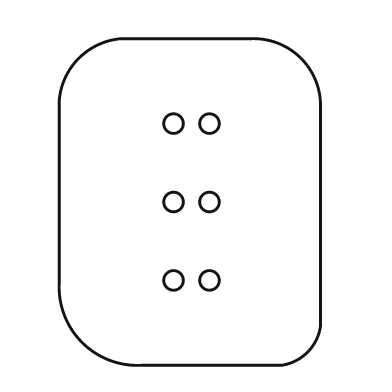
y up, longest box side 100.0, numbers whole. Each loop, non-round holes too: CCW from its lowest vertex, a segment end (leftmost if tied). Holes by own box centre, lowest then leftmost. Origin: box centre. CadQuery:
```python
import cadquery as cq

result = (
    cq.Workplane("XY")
    .moveTo(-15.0, -50.0)
    .lineTo(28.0, -50.0)
    .threePointArc((36.0, -46.0), (40.0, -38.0))
    .lineTo(40.0, 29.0)
    .threePointArc((34.0, 44.0), (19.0, 50.0))
    .lineTo(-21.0, 50.0)
    .threePointArc((-34.0, 44.0), (-40.0, 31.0))
    .lineTo(-40.0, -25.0)
    .threePointArc((-33.0, -43.0), (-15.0, -50.0))
    .close()
    .moveTo(-5.0, -24.0)
    .circle(3.0)
    .moveTo(6.0, -24.0)
    .circle(3.0)
    .moveTo(-5.0, 0.0)
    .circle(3.0)
    .moveTo(6.0, 0.0)
    .circle(3.0)
    .moveTo(-5.0, 24.0)
    .circle(3.0)
    .moveTo(6.0, 24.0)
    .circle(3.0)
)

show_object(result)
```